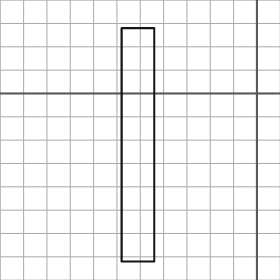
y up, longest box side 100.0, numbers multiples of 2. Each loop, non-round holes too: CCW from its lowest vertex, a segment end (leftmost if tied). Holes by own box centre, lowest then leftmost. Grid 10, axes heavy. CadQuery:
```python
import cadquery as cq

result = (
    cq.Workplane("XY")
    .moveTo(-58.0, -72.0)
    .lineTo(-44.0, -72.0)
    .lineTo(-44.0, 28.0)
    .lineTo(-58.0, 28.0)
    .close()
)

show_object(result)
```